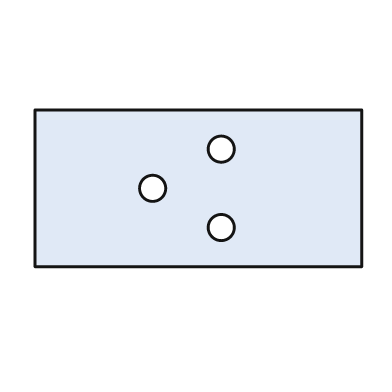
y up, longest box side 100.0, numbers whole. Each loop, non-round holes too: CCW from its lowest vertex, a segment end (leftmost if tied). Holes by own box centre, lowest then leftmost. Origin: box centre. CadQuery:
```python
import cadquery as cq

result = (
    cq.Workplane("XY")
    .moveTo(-50.0, -24.0)
    .lineTo(50.0, -24.0)
    .lineTo(50.0, 24.0)
    .lineTo(-50.0, 24.0)
    .close()
    .moveTo(7.0, -12.0)
    .circle(4.0)
    .moveTo(-14.0, 0.0)
    .circle(4.0)
    .moveTo(7.0, 12.0)
    .circle(4.0)
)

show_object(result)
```